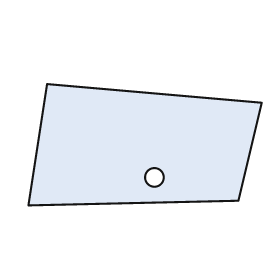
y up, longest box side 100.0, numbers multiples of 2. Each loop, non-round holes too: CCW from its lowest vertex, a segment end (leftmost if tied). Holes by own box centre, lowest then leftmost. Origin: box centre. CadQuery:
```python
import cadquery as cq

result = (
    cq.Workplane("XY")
    .moveTo(-50.0, -26.0)
    .lineTo(40.0, -24.0)
    .lineTo(50.0, 18.0)
    .lineTo(-42.0, 26.0)
    .close()
    .moveTo(4.0, -14.0)
    .circle(4.0)
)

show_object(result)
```